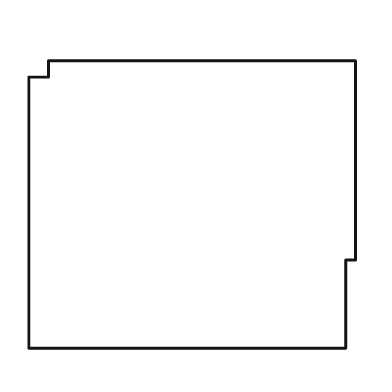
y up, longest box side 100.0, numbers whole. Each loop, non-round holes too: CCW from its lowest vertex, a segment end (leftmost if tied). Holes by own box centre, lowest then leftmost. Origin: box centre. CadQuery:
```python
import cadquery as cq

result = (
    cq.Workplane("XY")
    .moveTo(-50.0, -44.0)
    .lineTo(47.0, -44.0)
    .lineTo(47.0, -17.0)
    .lineTo(50.0, -17.0)
    .lineTo(50.0, 44.0)
    .lineTo(-44.0, 44.0)
    .lineTo(-44.0, 39.0)
    .lineTo(-50.0, 39.0)
    .close()
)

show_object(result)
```